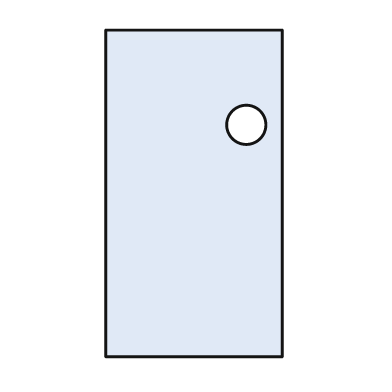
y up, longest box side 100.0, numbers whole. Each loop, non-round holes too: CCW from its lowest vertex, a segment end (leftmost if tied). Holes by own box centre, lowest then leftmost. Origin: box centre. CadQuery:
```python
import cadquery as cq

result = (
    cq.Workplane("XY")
    .moveTo(-27.0, -50.0)
    .lineTo(27.0, -50.0)
    .lineTo(27.0, 50.0)
    .lineTo(-27.0, 50.0)
    .close()
    .moveTo(16.0, 21.0)
    .circle(6.0)
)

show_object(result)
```